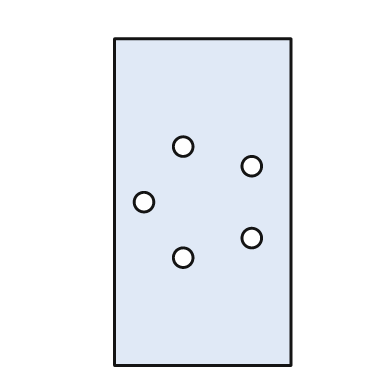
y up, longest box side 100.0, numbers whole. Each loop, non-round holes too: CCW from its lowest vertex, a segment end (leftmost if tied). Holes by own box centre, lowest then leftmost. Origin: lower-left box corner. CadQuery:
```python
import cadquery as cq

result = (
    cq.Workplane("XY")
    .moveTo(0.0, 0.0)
    .lineTo(54.0, 0.0)
    .lineTo(54.0, 100.0)
    .lineTo(0.0, 100.0)
    .close()
    .moveTo(21.0, 33.0)
    .circle(3.0)
    .moveTo(42.0, 39.0)
    .circle(3.0)
    .moveTo(9.0, 50.0)
    .circle(3.0)
    .moveTo(42.0, 61.0)
    .circle(3.0)
    .moveTo(21.0, 67.0)
    .circle(3.0)
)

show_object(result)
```